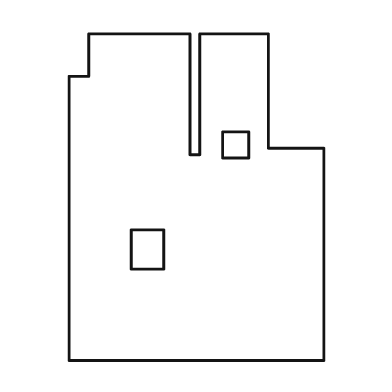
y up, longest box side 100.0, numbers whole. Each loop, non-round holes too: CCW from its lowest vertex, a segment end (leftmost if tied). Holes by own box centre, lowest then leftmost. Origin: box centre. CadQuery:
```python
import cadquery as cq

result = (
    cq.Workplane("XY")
    .moveTo(-39.0, -50.0)
    .lineTo(39.0, -50.0)
    .lineTo(39.0, 15.0)
    .lineTo(22.0, 15.0)
    .lineTo(22.0, 50.0)
    .lineTo(1.0, 50.0)
    .lineTo(1.0, 13.0)
    .lineTo(-2.0, 13.0)
    .lineTo(-2.0, 50.0)
    .lineTo(-33.0, 50.0)
    .lineTo(-33.0, 37.0)
    .lineTo(-39.0, 37.0)
    .close()
    .moveTo(-20.0, -22.0)
    .lineTo(-10.0, -22.0)
    .lineTo(-10.0, -10.0)
    .lineTo(-20.0, -10.0)
    .close()
    .moveTo(8.0, 12.0)
    .lineTo(16.0, 12.0)
    .lineTo(16.0, 20.0)
    .lineTo(8.0, 20.0)
    .close()
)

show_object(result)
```